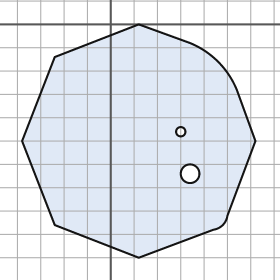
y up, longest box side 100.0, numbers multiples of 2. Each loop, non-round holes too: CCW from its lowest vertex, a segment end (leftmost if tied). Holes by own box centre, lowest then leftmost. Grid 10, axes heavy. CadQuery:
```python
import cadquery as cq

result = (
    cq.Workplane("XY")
    .moveTo(12.0, -100.0)
    .lineTo(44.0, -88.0)
    .threePointArc((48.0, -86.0), (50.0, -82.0))
    .lineTo(62.0, -50.0)
    .lineTo(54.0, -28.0)
    .threePointArc((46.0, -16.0), (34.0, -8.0))
    .lineTo(12.0, 0.0)
    .lineTo(-24.0, -14.0)
    .lineTo(-38.0, -50.0)
    .lineTo(-24.0, -86.0)
    .close()
    .moveTo(34.0, -64.0)
    .circle(4.0)
    .moveTo(30.0, -46.0)
    .circle(2.0)
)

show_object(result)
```